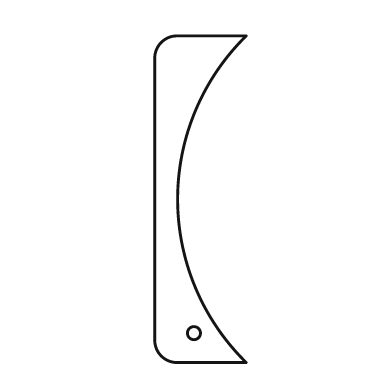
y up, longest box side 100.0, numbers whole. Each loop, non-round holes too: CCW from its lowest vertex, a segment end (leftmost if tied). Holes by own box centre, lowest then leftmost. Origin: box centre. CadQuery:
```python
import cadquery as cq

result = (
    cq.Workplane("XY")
    .moveTo(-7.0, -50.0)
    .lineTo(14.0, -50.0)
    .threePointArc((-7.0, 0.0), (14.0, 50.0))
    .lineTo(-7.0, 50.0)
    .threePointArc((-12.0, 48.0), (-14.0, 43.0))
    .lineTo(-14.0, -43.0)
    .threePointArc((-12.0, -48.0), (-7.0, -50.0))
    .close()
    .moveTo(-2.0, -41.0)
    .circle(2.0)
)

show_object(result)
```